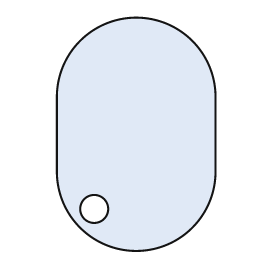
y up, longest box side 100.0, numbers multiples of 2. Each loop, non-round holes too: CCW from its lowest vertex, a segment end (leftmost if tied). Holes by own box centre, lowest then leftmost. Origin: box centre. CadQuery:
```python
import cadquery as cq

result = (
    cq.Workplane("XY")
    .moveTo(-34.0, -16.0)
    .threePointArc((0.0, -50.0), (34.0, -16.0))
    .lineTo(34.0, 16.0)
    .threePointArc((0.0, 50.0), (-34.0, 16.0))
    .close()
    .moveTo(-18.0, -32.0)
    .circle(6.0)
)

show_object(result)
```